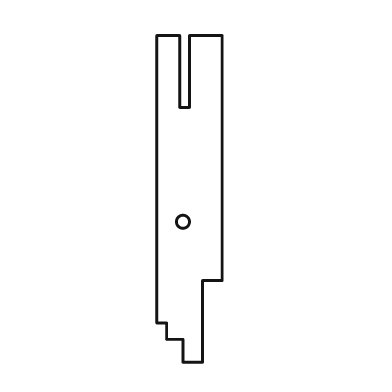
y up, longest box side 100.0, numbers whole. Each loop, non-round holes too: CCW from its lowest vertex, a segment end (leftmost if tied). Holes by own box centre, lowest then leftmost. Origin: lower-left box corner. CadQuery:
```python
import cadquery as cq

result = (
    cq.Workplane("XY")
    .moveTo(8.0, 0.0)
    .lineTo(14.0, 0.0)
    .lineTo(14.0, 25.0)
    .lineTo(20.0, 25.0)
    .lineTo(20.0, 100.0)
    .lineTo(10.0, 100.0)
    .lineTo(10.0, 78.0)
    .lineTo(7.0, 78.0)
    .lineTo(7.0, 100.0)
    .lineTo(0.0, 100.0)
    .lineTo(0.0, 12.0)
    .lineTo(3.0, 12.0)
    .lineTo(3.0, 7.0)
    .lineTo(8.0, 7.0)
    .close()
    .moveTo(8.0, 43.0)
    .circle(2.0)
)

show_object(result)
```